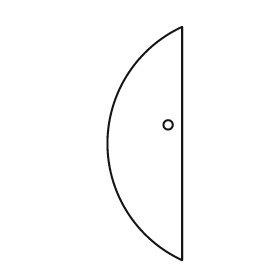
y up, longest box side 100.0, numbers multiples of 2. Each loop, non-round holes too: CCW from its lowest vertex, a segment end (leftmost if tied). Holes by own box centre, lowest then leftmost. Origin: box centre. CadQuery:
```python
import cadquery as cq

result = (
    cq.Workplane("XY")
    .moveTo(16.0, -50.0)
    .lineTo(16.0, 50.0)
    .threePointArc((-16.0, 0.0), (16.0, -50.0))
    .close()
    .moveTo(10.0, 8.0)
    .circle(2.0)
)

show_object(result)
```